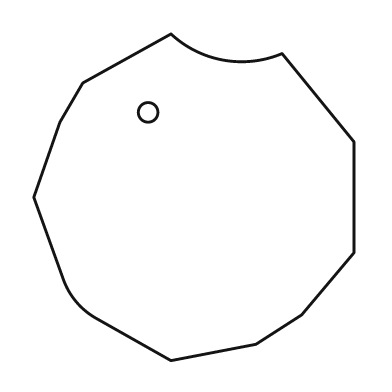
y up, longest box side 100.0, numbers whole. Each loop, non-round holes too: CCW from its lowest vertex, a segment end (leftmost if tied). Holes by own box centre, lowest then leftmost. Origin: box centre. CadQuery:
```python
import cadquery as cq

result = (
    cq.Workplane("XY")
    .moveTo(-7.0, -50.0)
    .lineTo(19.0, -45.0)
    .lineTo(33.0, -36.0)
    .lineTo(49.0, -17.0)
    .lineTo(49.0, 17.0)
    .lineTo(27.0, 44.0)
    .threePointArc((9.0, 42.0), (-7.0, 50.0))
    .lineTo(-34.0, 35.0)
    .lineTo(-41.0, 23.0)
    .lineTo(-49.0, 0.0)
    .lineTo(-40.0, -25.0)
    .threePointArc((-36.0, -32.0), (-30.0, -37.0))
    .close()
    .moveTo(-14.0, 26.0)
    .circle(3.0)
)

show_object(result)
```